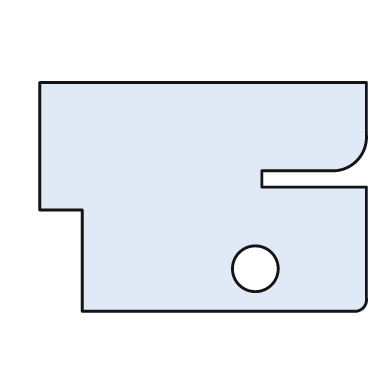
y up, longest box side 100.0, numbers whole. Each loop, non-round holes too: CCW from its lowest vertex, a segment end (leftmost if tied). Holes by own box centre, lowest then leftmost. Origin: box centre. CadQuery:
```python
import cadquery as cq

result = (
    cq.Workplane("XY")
    .moveTo(-37.0, -35.0)
    .lineTo(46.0, -35.0)
    .threePointArc((49.0, -34.0), (50.0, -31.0))
    .lineTo(50.0, 3.0)
    .lineTo(18.0, 3.0)
    .lineTo(18.0, 8.0)
    .lineTo(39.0, 8.0)
    .threePointArc((47.0, 11.0), (50.0, 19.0))
    .lineTo(50.0, 35.0)
    .lineTo(-50.0, 35.0)
    .lineTo(-50.0, -4.0)
    .lineTo(-37.0, -4.0)
    .close()
    .moveTo(16.0, -22.0)
    .circle(7.0)
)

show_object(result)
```